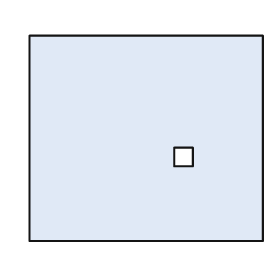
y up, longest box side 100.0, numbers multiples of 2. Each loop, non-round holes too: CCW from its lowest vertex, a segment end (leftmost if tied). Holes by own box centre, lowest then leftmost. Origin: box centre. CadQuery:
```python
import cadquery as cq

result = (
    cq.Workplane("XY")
    .moveTo(-50.0, -44.0)
    .lineTo(50.0, -44.0)
    .lineTo(50.0, 44.0)
    .lineTo(-50.0, 44.0)
    .close()
    .moveTo(12.0, -12.0)
    .lineTo(20.0, -12.0)
    .lineTo(20.0, -4.0)
    .lineTo(12.0, -4.0)
    .close()
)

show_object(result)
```